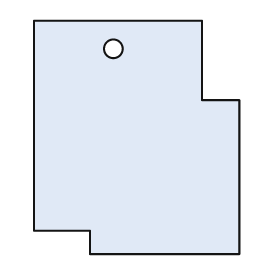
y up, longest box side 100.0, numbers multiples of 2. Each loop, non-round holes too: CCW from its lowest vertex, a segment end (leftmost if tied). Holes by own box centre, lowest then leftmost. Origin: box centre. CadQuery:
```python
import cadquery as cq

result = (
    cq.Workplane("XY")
    .moveTo(-20.0, -50.0)
    .lineTo(44.0, -50.0)
    .lineTo(44.0, 16.0)
    .lineTo(28.0, 16.0)
    .lineTo(28.0, 50.0)
    .lineTo(-44.0, 50.0)
    .lineTo(-44.0, -40.0)
    .lineTo(-20.0, -40.0)
    .close()
    .moveTo(-10.0, 38.0)
    .circle(4.0)
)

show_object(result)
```